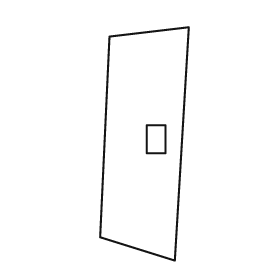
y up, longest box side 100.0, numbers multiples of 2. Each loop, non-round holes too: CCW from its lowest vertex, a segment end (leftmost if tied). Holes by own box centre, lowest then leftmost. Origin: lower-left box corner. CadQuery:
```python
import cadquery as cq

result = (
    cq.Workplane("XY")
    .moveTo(32.0, 0.0)
    .lineTo(38.0, 100.0)
    .lineTo(4.0, 96.0)
    .lineTo(0.0, 10.0)
    .close()
    .moveTo(20.0, 46.0)
    .lineTo(28.0, 46.0)
    .lineTo(28.0, 58.0)
    .lineTo(20.0, 58.0)
    .close()
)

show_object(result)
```